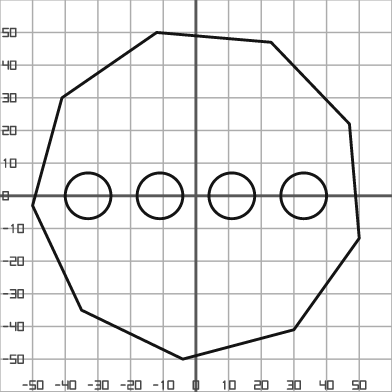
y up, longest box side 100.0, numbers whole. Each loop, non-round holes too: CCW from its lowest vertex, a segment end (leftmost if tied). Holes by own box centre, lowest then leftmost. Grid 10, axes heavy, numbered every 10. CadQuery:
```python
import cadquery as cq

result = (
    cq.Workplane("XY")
    .moveTo(-4.0, -50.0)
    .lineTo(30.0, -41.0)
    .lineTo(50.0, -13.0)
    .lineTo(47.0, 22.0)
    .lineTo(23.0, 47.0)
    .lineTo(-12.0, 50.0)
    .lineTo(-41.0, 30.0)
    .lineTo(-50.0, -3.0)
    .lineTo(-35.0, -35.0)
    .close()
    .moveTo(-33.0, 0.0)
    .circle(7.0)
    .moveTo(-11.0, 0.0)
    .circle(7.0)
    .moveTo(11.0, 0.0)
    .circle(7.0)
    .moveTo(33.0, 0.0)
    .circle(7.0)
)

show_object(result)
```